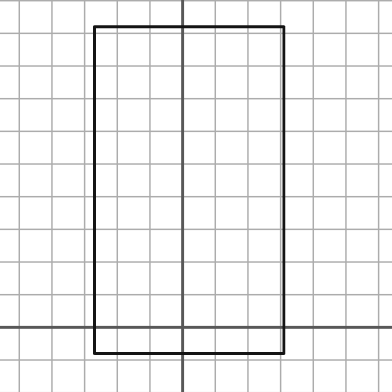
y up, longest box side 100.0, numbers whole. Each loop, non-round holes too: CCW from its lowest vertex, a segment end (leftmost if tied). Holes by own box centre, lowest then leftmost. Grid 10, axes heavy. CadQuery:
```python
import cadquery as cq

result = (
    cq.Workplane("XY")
    .moveTo(-27.0, -8.0)
    .lineTo(31.0, -8.0)
    .lineTo(31.0, 92.0)
    .lineTo(-27.0, 92.0)
    .close()
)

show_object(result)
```